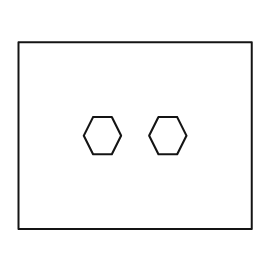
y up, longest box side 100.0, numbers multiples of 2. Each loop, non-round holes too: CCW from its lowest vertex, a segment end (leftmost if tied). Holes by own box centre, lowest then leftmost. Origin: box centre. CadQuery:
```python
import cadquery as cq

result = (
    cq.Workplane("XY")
    .moveTo(-50.0, -40.0)
    .lineTo(50.0, -40.0)
    .lineTo(50.0, 40.0)
    .lineTo(-50.0, 40.0)
    .close()
    .moveTo(-18.0, -8.0)
    .lineTo(-10.0, -8.0)
    .lineTo(-6.0, 0.0)
    .lineTo(-10.0, 8.0)
    .lineTo(-18.0, 8.0)
    .lineTo(-22.0, 0.0)
    .close()
    .moveTo(10.0, -8.0)
    .lineTo(18.0, -8.0)
    .lineTo(22.0, 0.0)
    .lineTo(18.0, 8.0)
    .lineTo(10.0, 8.0)
    .lineTo(6.0, 0.0)
    .close()
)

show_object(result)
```